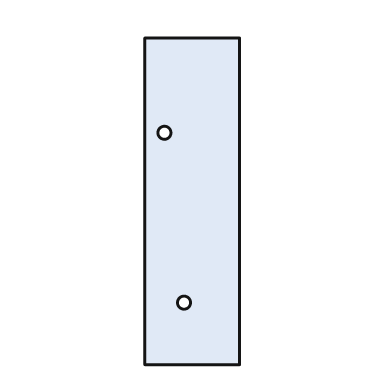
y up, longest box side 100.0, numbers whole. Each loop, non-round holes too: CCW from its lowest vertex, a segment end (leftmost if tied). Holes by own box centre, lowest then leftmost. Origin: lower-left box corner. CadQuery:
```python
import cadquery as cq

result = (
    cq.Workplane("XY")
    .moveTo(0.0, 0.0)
    .lineTo(29.0, 0.0)
    .lineTo(29.0, 100.0)
    .lineTo(0.0, 100.0)
    .close()
    .moveTo(12.0, 19.0)
    .circle(2.0)
    .moveTo(6.0, 71.0)
    .circle(2.0)
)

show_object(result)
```